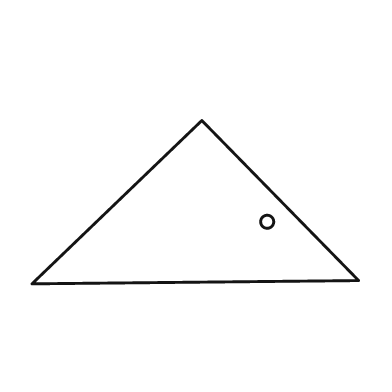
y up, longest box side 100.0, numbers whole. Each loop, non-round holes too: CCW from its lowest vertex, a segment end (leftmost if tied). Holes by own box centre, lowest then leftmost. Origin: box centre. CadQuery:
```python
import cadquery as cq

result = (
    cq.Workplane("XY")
    .moveTo(-50.0, -25.0)
    .lineTo(50.0, -24.0)
    .lineTo(2.0, 25.0)
    .close()
    .moveTo(22.0, -6.0)
    .circle(2.0)
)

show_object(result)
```